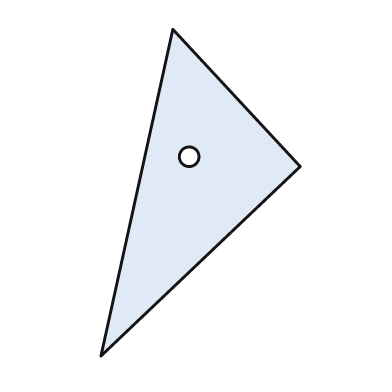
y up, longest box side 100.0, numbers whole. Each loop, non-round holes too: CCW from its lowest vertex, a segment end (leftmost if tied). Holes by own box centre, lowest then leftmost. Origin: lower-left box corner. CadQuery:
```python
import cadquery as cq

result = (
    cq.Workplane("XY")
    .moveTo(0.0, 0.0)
    .lineTo(61.0, 58.0)
    .lineTo(22.0, 100.0)
    .close()
    .moveTo(27.0, 61.0)
    .circle(3.0)
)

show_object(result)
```